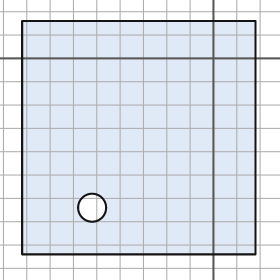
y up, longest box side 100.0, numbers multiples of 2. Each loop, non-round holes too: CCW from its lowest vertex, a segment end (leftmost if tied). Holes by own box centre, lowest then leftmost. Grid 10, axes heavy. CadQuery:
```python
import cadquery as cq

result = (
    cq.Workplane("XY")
    .moveTo(-82.0, -84.0)
    .lineTo(18.0, -84.0)
    .lineTo(18.0, 16.0)
    .lineTo(-82.0, 16.0)
    .close()
    .moveTo(-52.0, -64.0)
    .circle(6.0)
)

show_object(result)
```